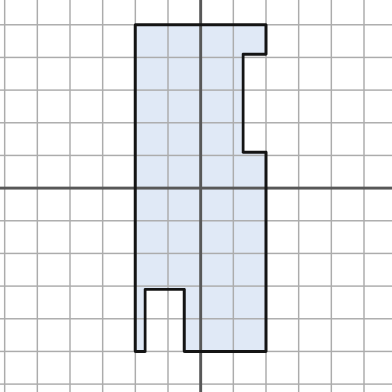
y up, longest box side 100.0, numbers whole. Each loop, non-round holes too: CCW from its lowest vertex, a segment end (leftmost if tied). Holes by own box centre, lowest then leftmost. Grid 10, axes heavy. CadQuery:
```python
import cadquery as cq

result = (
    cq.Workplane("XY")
    .moveTo(-20.0, -50.0)
    .lineTo(-17.0, -50.0)
    .lineTo(-17.0, -31.0)
    .lineTo(-5.0, -31.0)
    .lineTo(-5.0, -50.0)
    .lineTo(20.0, -50.0)
    .lineTo(20.0, 11.0)
    .lineTo(13.0, 11.0)
    .lineTo(13.0, 41.0)
    .lineTo(20.0, 41.0)
    .lineTo(20.0, 50.0)
    .lineTo(-20.0, 50.0)
    .close()
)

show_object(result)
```